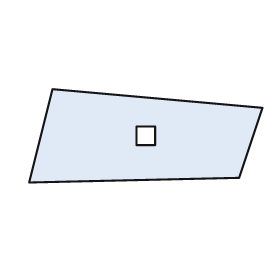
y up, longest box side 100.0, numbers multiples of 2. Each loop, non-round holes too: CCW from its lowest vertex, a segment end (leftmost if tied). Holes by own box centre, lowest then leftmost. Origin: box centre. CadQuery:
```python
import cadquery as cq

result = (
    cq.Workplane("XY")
    .moveTo(-50.0, -20.0)
    .lineTo(40.0, -18.0)
    .lineTo(50.0, 12.0)
    .lineTo(-40.0, 20.0)
    .close()
    .moveTo(-4.0, -4.0)
    .lineTo(4.0, -4.0)
    .lineTo(4.0, 4.0)
    .lineTo(-4.0, 4.0)
    .close()
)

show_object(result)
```